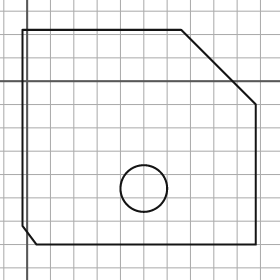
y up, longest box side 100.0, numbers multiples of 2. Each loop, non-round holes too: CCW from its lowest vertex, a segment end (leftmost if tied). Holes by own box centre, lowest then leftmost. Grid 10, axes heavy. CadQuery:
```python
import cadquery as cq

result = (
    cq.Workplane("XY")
    .moveTo(4.0, -70.0)
    .lineTo(98.0, -70.0)
    .lineTo(98.0, -10.0)
    .lineTo(66.0, 22.0)
    .lineTo(-2.0, 22.0)
    .lineTo(-2.0, -62.0)
    .close()
    .moveTo(50.0, -46.0)
    .circle(10.0)
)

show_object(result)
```